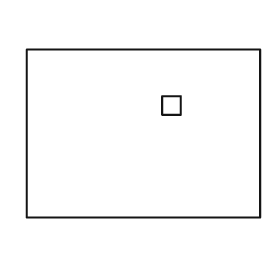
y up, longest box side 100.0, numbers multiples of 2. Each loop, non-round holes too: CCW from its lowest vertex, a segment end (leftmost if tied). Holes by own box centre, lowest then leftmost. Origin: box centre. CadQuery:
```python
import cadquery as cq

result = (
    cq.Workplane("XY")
    .moveTo(-50.0, -36.0)
    .lineTo(50.0, -36.0)
    .lineTo(50.0, 36.0)
    .lineTo(-50.0, 36.0)
    .close()
    .moveTo(8.0, 8.0)
    .lineTo(16.0, 8.0)
    .lineTo(16.0, 16.0)
    .lineTo(8.0, 16.0)
    .close()
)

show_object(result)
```